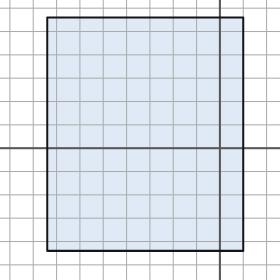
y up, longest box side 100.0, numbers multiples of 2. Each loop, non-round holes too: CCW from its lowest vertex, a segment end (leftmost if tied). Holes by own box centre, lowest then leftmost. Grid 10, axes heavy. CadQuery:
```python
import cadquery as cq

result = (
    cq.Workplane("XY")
    .moveTo(-74.0, -44.0)
    .lineTo(10.0, -44.0)
    .lineTo(10.0, 56.0)
    .lineTo(-74.0, 56.0)
    .close()
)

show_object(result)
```